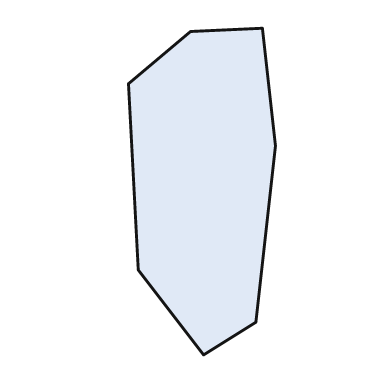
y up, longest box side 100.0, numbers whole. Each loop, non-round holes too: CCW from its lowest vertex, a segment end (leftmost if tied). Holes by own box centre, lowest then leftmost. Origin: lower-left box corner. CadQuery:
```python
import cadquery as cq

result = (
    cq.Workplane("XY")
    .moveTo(23.0, 0.0)
    .lineTo(39.0, 10.0)
    .lineTo(45.0, 64.0)
    .lineTo(41.0, 100.0)
    .lineTo(19.0, 99.0)
    .lineTo(0.0, 83.0)
    .lineTo(3.0, 26.0)
    .close()
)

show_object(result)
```